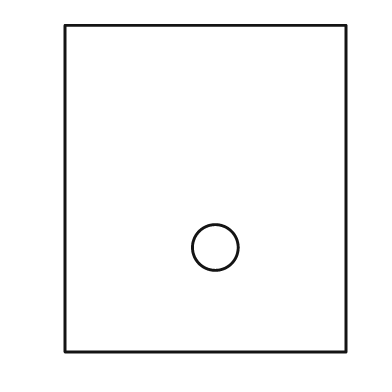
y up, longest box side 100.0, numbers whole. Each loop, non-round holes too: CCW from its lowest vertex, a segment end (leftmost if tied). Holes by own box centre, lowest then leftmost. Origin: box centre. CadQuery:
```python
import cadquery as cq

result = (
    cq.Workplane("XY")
    .moveTo(-43.0, -50.0)
    .lineTo(43.0, -50.0)
    .lineTo(43.0, 50.0)
    .lineTo(-43.0, 50.0)
    .close()
    .moveTo(3.0, -18.0)
    .circle(7.0)
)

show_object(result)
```